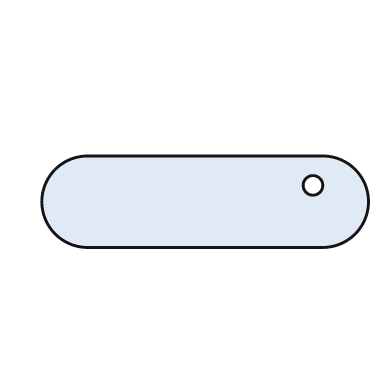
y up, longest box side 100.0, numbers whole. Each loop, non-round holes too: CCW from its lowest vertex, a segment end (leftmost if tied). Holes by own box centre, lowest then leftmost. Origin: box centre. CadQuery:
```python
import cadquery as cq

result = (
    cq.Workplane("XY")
    .moveTo(-36.0, -14.0)
    .lineTo(36.0, -14.0)
    .threePointArc((50.0, 0.0), (36.0, 14.0))
    .lineTo(-36.0, 14.0)
    .threePointArc((-50.0, 0.0), (-36.0, -14.0))
    .close()
    .moveTo(33.0, 5.0)
    .circle(3.0)
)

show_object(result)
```